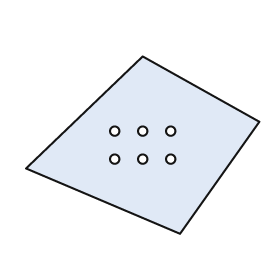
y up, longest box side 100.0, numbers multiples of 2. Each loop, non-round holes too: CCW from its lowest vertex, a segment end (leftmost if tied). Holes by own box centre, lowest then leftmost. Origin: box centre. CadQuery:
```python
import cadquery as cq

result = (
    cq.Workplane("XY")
    .moveTo(16.0, -38.0)
    .lineTo(50.0, 10.0)
    .lineTo(0.0, 38.0)
    .lineTo(-50.0, -10.0)
    .close()
    .moveTo(-12.0, -6.0)
    .circle(2.0)
    .moveTo(0.0, -6.0)
    .circle(2.0)
    .moveTo(12.0, -6.0)
    .circle(2.0)
    .moveTo(-12.0, 6.0)
    .circle(2.0)
    .moveTo(0.0, 6.0)
    .circle(2.0)
    .moveTo(12.0, 6.0)
    .circle(2.0)
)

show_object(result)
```